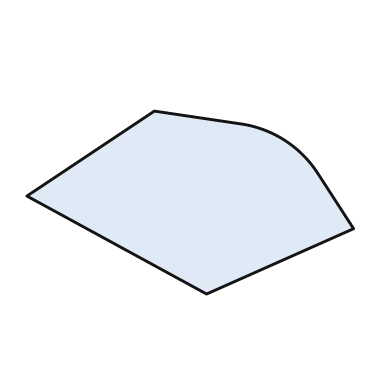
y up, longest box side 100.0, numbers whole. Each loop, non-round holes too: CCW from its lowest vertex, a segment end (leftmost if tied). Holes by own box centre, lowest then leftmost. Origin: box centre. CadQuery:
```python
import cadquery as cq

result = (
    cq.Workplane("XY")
    .moveTo(5.0, -28.0)
    .lineTo(50.0, -8.0)
    .lineTo(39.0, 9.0)
    .threePointArc((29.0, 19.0), (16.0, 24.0))
    .lineTo(-11.0, 28.0)
    .lineTo(-50.0, 2.0)
    .close()
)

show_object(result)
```